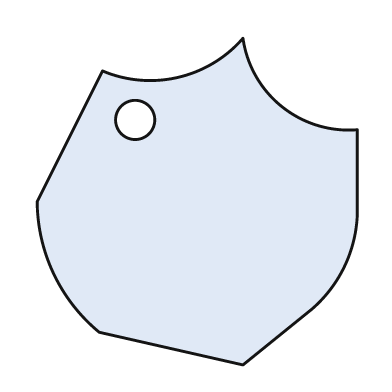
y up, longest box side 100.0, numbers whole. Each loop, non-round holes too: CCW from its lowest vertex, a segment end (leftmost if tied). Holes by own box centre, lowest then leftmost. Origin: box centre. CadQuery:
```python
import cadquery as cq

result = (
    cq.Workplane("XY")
    .moveTo(14.0, -50.0)
    .lineTo(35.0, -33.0)
    .threePointArc((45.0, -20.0), (49.0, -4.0))
    .lineTo(49.0, 22.0)
    .threePointArc((26.0, 29.0), (14.0, 50.0))
    .threePointArc((-6.0, 38.0), (-29.0, 40.0))
    .lineTo(-49.0, 0.0)
    .threePointArc((-44.0, -22.0), (-30.0, -40.0))
    .close()
    .moveTo(-19.0, 25.0)
    .circle(6.0)
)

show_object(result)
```